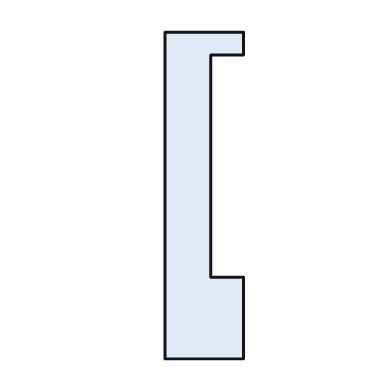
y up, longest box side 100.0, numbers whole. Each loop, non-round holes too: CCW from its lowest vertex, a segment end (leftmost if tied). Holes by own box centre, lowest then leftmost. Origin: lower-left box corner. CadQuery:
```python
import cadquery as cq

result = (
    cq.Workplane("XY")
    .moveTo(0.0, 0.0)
    .lineTo(24.0, 0.0)
    .lineTo(24.0, 25.0)
    .lineTo(14.0, 25.0)
    .lineTo(14.0, 93.0)
    .lineTo(24.0, 93.0)
    .lineTo(24.0, 100.0)
    .lineTo(0.0, 100.0)
    .close()
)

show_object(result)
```